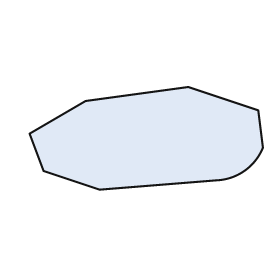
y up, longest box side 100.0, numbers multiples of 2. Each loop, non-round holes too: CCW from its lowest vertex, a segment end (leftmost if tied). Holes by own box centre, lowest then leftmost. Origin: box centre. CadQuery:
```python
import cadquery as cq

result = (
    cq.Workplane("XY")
    .moveTo(-20.0, -22.0)
    .lineTo(30.0, -18.0)
    .threePointArc((42.0, -14.0), (50.0, -4.0))
    .lineTo(48.0, 12.0)
    .lineTo(18.0, 22.0)
    .lineTo(-26.0, 16.0)
    .lineTo(-50.0, 2.0)
    .lineTo(-44.0, -14.0)
    .close()
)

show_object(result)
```